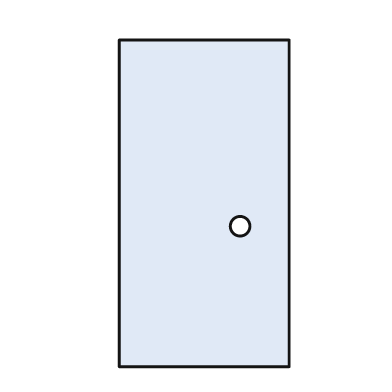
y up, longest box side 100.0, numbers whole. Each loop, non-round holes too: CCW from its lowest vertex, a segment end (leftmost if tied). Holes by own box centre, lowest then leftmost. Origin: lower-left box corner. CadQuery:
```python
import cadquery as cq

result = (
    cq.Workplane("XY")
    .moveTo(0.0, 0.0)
    .lineTo(52.0, 0.0)
    .lineTo(52.0, 100.0)
    .lineTo(0.0, 100.0)
    .close()
    .moveTo(37.0, 43.0)
    .circle(3.0)
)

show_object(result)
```